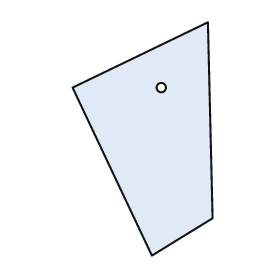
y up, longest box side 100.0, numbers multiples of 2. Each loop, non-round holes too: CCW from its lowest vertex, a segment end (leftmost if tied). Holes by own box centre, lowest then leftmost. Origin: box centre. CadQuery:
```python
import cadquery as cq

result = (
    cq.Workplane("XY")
    .moveTo(4.0, -50.0)
    .lineTo(30.0, -34.0)
    .lineTo(28.0, 50.0)
    .lineTo(-30.0, 22.0)
    .close()
    .moveTo(8.0, 22.0)
    .circle(2.0)
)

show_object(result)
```